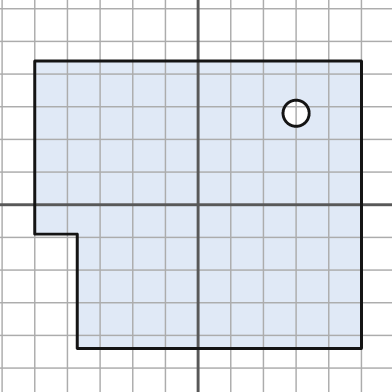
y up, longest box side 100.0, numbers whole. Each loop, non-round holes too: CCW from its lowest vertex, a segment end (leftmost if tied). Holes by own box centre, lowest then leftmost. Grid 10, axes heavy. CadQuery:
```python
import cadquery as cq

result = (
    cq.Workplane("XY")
    .moveTo(-37.0, -44.0)
    .lineTo(50.0, -44.0)
    .lineTo(50.0, 44.0)
    .lineTo(-50.0, 44.0)
    .lineTo(-50.0, -9.0)
    .lineTo(-37.0, -9.0)
    .close()
    .moveTo(30.0, 28.0)
    .circle(4.0)
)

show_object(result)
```